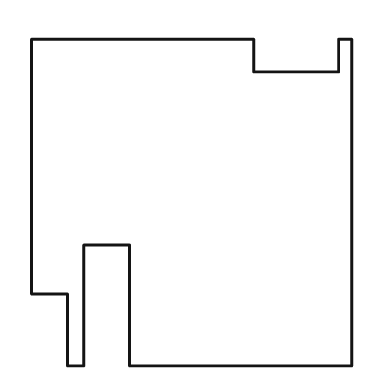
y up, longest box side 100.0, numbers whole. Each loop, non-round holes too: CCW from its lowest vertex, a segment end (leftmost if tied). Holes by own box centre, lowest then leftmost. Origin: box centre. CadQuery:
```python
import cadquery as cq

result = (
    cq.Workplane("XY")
    .moveTo(-38.0, -50.0)
    .lineTo(-33.0, -50.0)
    .lineTo(-33.0, -13.0)
    .lineTo(-19.0, -13.0)
    .lineTo(-19.0, -50.0)
    .lineTo(49.0, -50.0)
    .lineTo(49.0, 50.0)
    .lineTo(45.0, 50.0)
    .lineTo(45.0, 40.0)
    .lineTo(19.0, 40.0)
    .lineTo(19.0, 50.0)
    .lineTo(-49.0, 50.0)
    .lineTo(-49.0, -28.0)
    .lineTo(-38.0, -28.0)
    .close()
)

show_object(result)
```